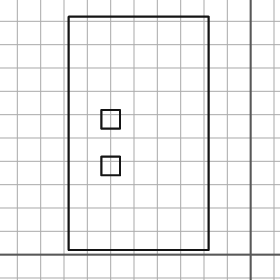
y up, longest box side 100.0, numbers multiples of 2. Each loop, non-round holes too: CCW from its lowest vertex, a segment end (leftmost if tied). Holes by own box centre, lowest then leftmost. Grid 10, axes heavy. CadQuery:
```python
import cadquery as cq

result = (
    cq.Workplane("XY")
    .moveTo(-78.0, 2.0)
    .lineTo(-18.0, 2.0)
    .lineTo(-18.0, 102.0)
    .lineTo(-78.0, 102.0)
    .close()
    .moveTo(-64.0, 34.0)
    .lineTo(-56.0, 34.0)
    .lineTo(-56.0, 42.0)
    .lineTo(-64.0, 42.0)
    .close()
    .moveTo(-64.0, 54.0)
    .lineTo(-56.0, 54.0)
    .lineTo(-56.0, 62.0)
    .lineTo(-64.0, 62.0)
    .close()
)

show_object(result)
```